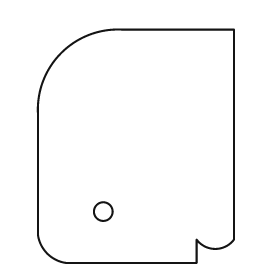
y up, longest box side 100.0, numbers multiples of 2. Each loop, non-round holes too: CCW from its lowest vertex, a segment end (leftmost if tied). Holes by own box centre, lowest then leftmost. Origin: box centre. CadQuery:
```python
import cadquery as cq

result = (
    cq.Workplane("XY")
    .moveTo(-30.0, -50.0)
    .lineTo(26.0, -50.0)
    .lineTo(26.0, -40.0)
    .threePointArc((34.0, -44.0), (42.0, -40.0))
    .lineTo(42.0, 50.0)
    .lineTo(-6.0, 50.0)
    .threePointArc((-32.0, 40.0), (-42.0, 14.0))
    .lineTo(-42.0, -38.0)
    .threePointArc((-38.0, -46.0), (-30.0, -50.0))
    .close()
    .moveTo(-14.0, -28.0)
    .circle(4.0)
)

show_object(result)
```